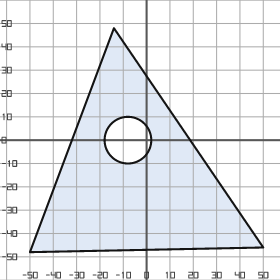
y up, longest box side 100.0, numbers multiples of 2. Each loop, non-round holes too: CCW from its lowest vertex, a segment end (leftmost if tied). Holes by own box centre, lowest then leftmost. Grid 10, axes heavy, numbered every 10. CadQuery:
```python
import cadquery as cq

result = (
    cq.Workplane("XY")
    .moveTo(-50.0, -48.0)
    .lineTo(50.0, -46.0)
    .lineTo(-14.0, 48.0)
    .close()
    .moveTo(-8.0, 0.0)
    .circle(10.0)
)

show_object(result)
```